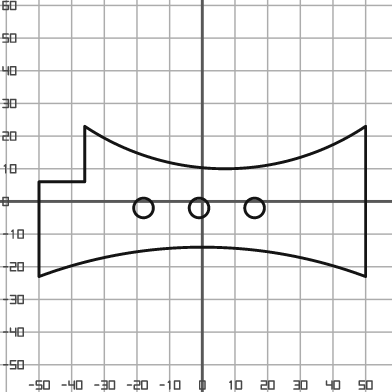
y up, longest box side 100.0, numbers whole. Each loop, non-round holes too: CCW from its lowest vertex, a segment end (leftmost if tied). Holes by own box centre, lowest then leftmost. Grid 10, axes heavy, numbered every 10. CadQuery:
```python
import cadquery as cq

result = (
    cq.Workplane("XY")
    .moveTo(-50.0, -23.0)
    .threePointArc((0.0, -14.0), (50.0, -23.0))
    .lineTo(50.0, 23.0)
    .threePointArc((7.0, 10.0), (-36.0, 23.0))
    .lineTo(-36.0, 6.0)
    .lineTo(-50.0, 6.0)
    .close()
    .moveTo(-18.0, -2.0)
    .circle(3.0)
    .moveTo(-1.0, -2.0)
    .circle(3.0)
    .moveTo(16.0, -2.0)
    .circle(3.0)
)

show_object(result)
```